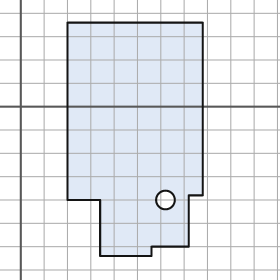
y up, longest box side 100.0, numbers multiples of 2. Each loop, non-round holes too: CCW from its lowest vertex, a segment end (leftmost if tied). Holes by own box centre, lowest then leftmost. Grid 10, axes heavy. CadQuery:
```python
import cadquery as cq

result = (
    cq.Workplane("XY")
    .moveTo(34.0, -64.0)
    .lineTo(56.0, -64.0)
    .lineTo(56.0, -60.0)
    .lineTo(72.0, -60.0)
    .lineTo(72.0, -38.0)
    .lineTo(78.0, -38.0)
    .lineTo(78.0, 36.0)
    .lineTo(20.0, 36.0)
    .lineTo(20.0, -40.0)
    .lineTo(34.0, -40.0)
    .close()
    .moveTo(62.0, -40.0)
    .circle(4.0)
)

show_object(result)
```